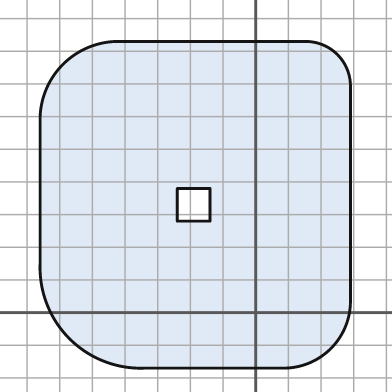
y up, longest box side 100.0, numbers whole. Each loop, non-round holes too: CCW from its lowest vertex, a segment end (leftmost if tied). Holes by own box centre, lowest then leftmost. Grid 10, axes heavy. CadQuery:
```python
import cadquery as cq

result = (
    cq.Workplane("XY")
    .moveTo(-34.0, -17.0)
    .lineTo(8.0, -17.0)
    .threePointArc((23.0, -11.0), (29.0, 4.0))
    .lineTo(29.0, 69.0)
    .threePointArc((25.0, 79.0), (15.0, 83.0))
    .lineTo(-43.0, 83.0)
    .threePointArc((-59.0, 76.0), (-66.0, 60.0))
    .lineTo(-66.0, 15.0)
    .threePointArc((-57.0, -8.0), (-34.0, -17.0))
    .close()
    .moveTo(-24.0, 28.0)
    .lineTo(-14.0, 28.0)
    .lineTo(-14.0, 38.0)
    .lineTo(-24.0, 38.0)
    .close()
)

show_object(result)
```